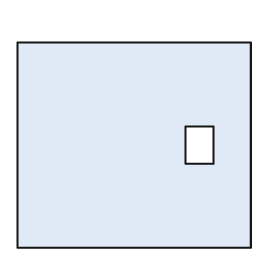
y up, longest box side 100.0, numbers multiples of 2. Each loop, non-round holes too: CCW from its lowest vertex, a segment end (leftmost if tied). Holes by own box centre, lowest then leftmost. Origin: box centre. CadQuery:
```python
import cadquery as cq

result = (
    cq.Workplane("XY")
    .moveTo(-50.0, -44.0)
    .lineTo(50.0, -44.0)
    .lineTo(50.0, 44.0)
    .lineTo(-50.0, 44.0)
    .close()
    .moveTo(22.0, -8.0)
    .lineTo(34.0, -8.0)
    .lineTo(34.0, 8.0)
    .lineTo(22.0, 8.0)
    .close()
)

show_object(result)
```